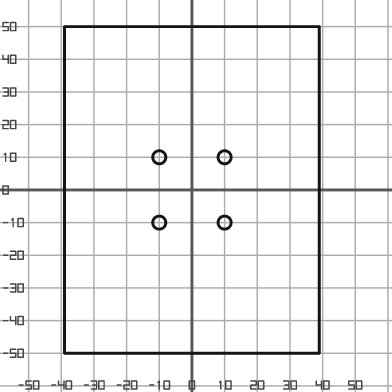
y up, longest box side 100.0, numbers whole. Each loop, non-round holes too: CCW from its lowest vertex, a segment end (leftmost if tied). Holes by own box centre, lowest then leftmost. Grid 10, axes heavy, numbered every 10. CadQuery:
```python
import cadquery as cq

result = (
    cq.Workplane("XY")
    .moveTo(-39.0, -50.0)
    .lineTo(39.0, -50.0)
    .lineTo(39.0, 50.0)
    .lineTo(-39.0, 50.0)
    .close()
    .moveTo(-10.0, -10.0)
    .circle(2.0)
    .moveTo(10.0, -10.0)
    .circle(2.0)
    .moveTo(-10.0, 10.0)
    .circle(2.0)
    .moveTo(10.0, 10.0)
    .circle(2.0)
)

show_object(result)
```